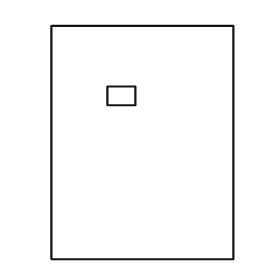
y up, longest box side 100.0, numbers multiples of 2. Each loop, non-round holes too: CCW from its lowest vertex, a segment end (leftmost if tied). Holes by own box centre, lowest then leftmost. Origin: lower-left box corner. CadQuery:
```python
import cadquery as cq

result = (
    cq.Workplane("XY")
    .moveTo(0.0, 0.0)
    .lineTo(78.0, 0.0)
    .lineTo(78.0, 100.0)
    .lineTo(0.0, 100.0)
    .close()
    .moveTo(24.0, 66.0)
    .lineTo(36.0, 66.0)
    .lineTo(36.0, 74.0)
    .lineTo(24.0, 74.0)
    .close()
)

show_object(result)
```